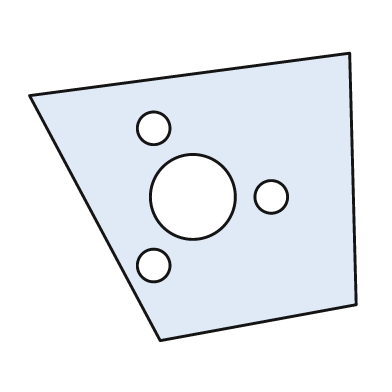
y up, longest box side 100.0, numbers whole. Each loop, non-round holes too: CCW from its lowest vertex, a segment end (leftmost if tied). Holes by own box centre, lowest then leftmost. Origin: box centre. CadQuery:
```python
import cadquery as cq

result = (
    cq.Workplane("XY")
    .moveTo(-10.0, -44.0)
    .lineTo(50.0, -33.0)
    .lineTo(48.0, 44.0)
    .lineTo(-50.0, 31.0)
    .close()
    .moveTo(-12.0, -21.0)
    .circle(5.0)
    .moveTo(0.0, 0.0)
    .circle(13.0)
    .moveTo(24.0, 0.0)
    .circle(5.0)
    .moveTo(-12.0, 21.0)
    .circle(5.0)
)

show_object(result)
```